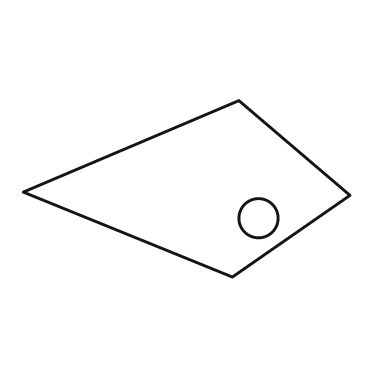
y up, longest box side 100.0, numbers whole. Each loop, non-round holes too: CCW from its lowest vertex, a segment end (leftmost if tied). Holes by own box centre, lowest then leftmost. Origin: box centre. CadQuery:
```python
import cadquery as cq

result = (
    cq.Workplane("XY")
    .moveTo(14.0, -27.0)
    .lineTo(50.0, -2.0)
    .lineTo(16.0, 27.0)
    .lineTo(-50.0, -1.0)
    .close()
    .moveTo(22.0, -9.0)
    .circle(6.0)
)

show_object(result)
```